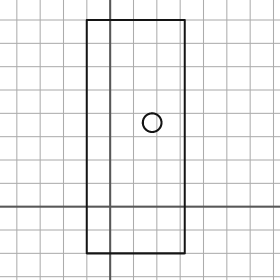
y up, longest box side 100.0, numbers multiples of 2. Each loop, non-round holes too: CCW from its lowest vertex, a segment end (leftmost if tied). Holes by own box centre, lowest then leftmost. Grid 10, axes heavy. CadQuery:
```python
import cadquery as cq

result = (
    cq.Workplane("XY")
    .moveTo(-10.0, -20.0)
    .lineTo(32.0, -20.0)
    .lineTo(32.0, 80.0)
    .lineTo(-10.0, 80.0)
    .close()
    .moveTo(18.0, 36.0)
    .circle(4.0)
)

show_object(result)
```